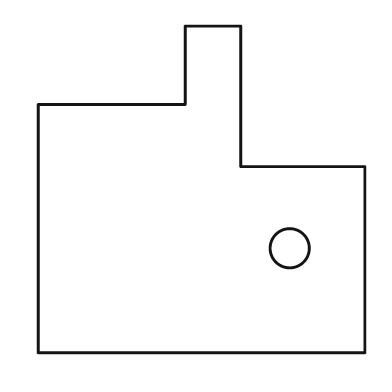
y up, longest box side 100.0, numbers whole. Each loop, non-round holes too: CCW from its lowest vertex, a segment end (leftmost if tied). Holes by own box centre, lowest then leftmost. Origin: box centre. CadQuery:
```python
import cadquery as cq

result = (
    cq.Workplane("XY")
    .moveTo(-50.0, -50.0)
    .lineTo(50.0, -50.0)
    .lineTo(50.0, 7.0)
    .lineTo(12.0, 7.0)
    .lineTo(12.0, 50.0)
    .lineTo(-5.0, 50.0)
    .lineTo(-5.0, 26.0)
    .lineTo(-50.0, 26.0)
    .close()
    .moveTo(27.0, -18.0)
    .circle(6.0)
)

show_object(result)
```